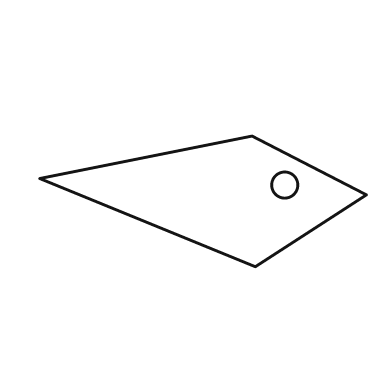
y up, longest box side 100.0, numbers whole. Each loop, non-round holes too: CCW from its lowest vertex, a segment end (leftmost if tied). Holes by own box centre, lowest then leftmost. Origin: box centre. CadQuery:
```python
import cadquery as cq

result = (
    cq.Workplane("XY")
    .moveTo(16.0, -20.0)
    .lineTo(50.0, 2.0)
    .lineTo(15.0, 20.0)
    .lineTo(-50.0, 7.0)
    .close()
    .moveTo(25.0, 5.0)
    .circle(4.0)
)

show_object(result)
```